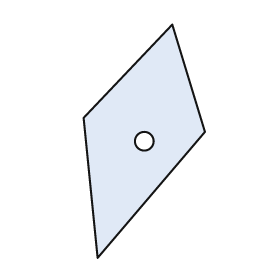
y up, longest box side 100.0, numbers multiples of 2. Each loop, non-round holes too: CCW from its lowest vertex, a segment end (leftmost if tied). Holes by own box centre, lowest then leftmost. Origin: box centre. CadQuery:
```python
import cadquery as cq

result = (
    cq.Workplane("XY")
    .moveTo(-20.0, -50.0)
    .lineTo(26.0, 4.0)
    .lineTo(12.0, 50.0)
    .lineTo(-26.0, 10.0)
    .close()
    .moveTo(0.0, 0.0)
    .circle(4.0)
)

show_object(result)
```